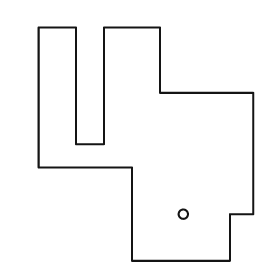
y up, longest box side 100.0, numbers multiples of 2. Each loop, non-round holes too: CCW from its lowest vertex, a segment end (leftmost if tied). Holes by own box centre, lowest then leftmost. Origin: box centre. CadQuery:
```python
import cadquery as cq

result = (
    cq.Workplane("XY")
    .moveTo(-6.0, -50.0)
    .lineTo(36.0, -50.0)
    .lineTo(36.0, -30.0)
    .lineTo(46.0, -30.0)
    .lineTo(46.0, 22.0)
    .lineTo(6.0, 22.0)
    .lineTo(6.0, 50.0)
    .lineTo(-18.0, 50.0)
    .lineTo(-18.0, 0.0)
    .lineTo(-30.0, 0.0)
    .lineTo(-30.0, 50.0)
    .lineTo(-46.0, 50.0)
    .lineTo(-46.0, -10.0)
    .lineTo(-6.0, -10.0)
    .close()
    .moveTo(16.0, -30.0)
    .circle(2.0)
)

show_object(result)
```